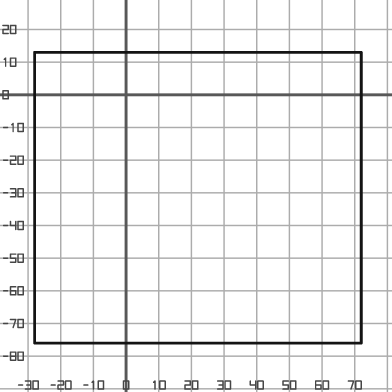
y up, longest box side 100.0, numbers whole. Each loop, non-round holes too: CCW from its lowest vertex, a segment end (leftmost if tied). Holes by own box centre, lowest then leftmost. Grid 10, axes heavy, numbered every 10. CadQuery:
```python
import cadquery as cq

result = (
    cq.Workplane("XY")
    .moveTo(-28.0, -76.0)
    .lineTo(72.0, -76.0)
    .lineTo(72.0, 13.0)
    .lineTo(-28.0, 13.0)
    .close()
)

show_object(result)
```